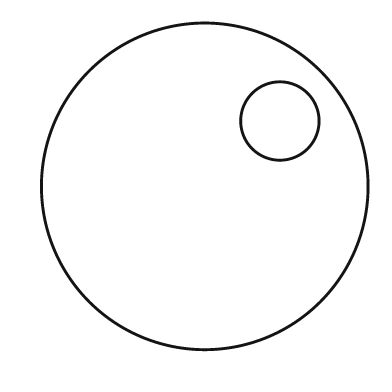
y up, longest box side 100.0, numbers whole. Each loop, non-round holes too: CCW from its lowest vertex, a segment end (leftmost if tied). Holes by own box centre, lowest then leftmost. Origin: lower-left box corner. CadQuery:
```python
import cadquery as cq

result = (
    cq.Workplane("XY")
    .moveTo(50.0, 50.0)
    .circle(50.0)
    .moveTo(73.0, 70.0)
    .circle(12.0)
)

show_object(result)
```